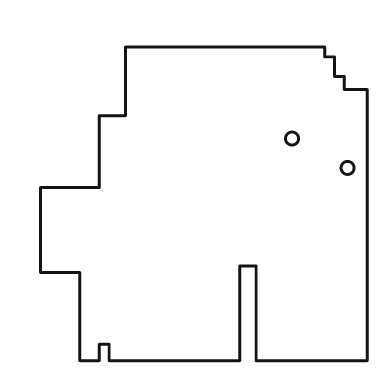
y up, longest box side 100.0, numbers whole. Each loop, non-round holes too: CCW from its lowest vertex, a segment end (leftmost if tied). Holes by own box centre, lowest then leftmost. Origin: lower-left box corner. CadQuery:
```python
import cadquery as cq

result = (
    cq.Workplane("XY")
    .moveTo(12.0, 0.0)
    .lineTo(18.0, 0.0)
    .lineTo(18.0, 5.0)
    .lineTo(21.0, 5.0)
    .lineTo(21.0, 0.0)
    .lineTo(61.0, 0.0)
    .lineTo(61.0, 29.0)
    .lineTo(66.0, 29.0)
    .lineTo(66.0, 0.0)
    .lineTo(100.0, 0.0)
    .lineTo(100.0, 83.0)
    .lineTo(93.0, 83.0)
    .lineTo(93.0, 87.0)
    .lineTo(90.0, 87.0)
    .lineTo(90.0, 93.0)
    .lineTo(87.0, 93.0)
    .lineTo(87.0, 96.0)
    .lineTo(26.0, 96.0)
    .lineTo(26.0, 75.0)
    .lineTo(18.0, 75.0)
    .lineTo(18.0, 53.0)
    .lineTo(0.0, 53.0)
    .lineTo(0.0, 27.0)
    .lineTo(12.0, 27.0)
    .close()
    .moveTo(94.0, 59.0)
    .circle(2.0)
    .moveTo(77.0, 68.0)
    .circle(2.0)
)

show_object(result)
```